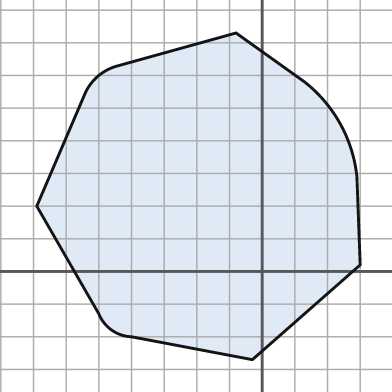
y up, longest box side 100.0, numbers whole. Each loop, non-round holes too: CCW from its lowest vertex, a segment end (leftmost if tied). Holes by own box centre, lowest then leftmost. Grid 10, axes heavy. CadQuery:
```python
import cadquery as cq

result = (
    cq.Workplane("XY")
    .moveTo(-3.0, -27.0)
    .lineTo(30.0, 2.0)
    .lineTo(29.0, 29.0)
    .threePointArc((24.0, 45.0), (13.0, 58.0))
    .lineTo(-8.0, 73.0)
    .lineTo(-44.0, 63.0)
    .threePointArc((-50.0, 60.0), (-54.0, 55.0))
    .lineTo(-69.0, 20.0)
    .lineTo(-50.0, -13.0)
    .threePointArc((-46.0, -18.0), (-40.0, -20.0))
    .close()
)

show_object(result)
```